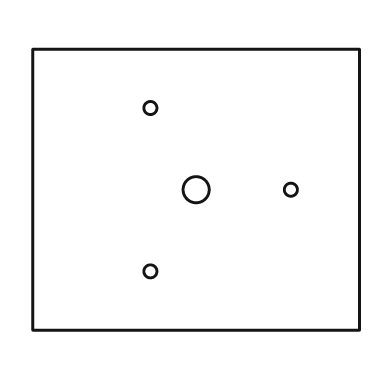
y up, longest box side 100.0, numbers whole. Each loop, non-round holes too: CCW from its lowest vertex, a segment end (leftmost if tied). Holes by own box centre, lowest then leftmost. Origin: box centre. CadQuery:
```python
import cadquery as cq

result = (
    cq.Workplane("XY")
    .moveTo(-50.0, -43.0)
    .lineTo(50.0, -43.0)
    .lineTo(50.0, 43.0)
    .lineTo(-50.0, 43.0)
    .close()
    .moveTo(-14.0, -25.0)
    .circle(2.0)
    .moveTo(0.0, 0.0)
    .circle(4.0)
    .moveTo(29.0, 0.0)
    .circle(2.0)
    .moveTo(-14.0, 25.0)
    .circle(2.0)
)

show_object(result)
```